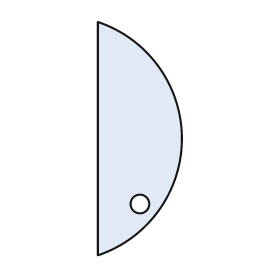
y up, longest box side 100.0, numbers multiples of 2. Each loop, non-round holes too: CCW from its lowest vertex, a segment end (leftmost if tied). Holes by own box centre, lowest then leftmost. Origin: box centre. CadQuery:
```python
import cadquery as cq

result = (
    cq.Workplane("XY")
    .moveTo(-18.0, -50.0)
    .threePointArc((18.0, 0.0), (-18.0, 50.0))
    .close()
    .moveTo(0.0, -28.0)
    .circle(4.0)
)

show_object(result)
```